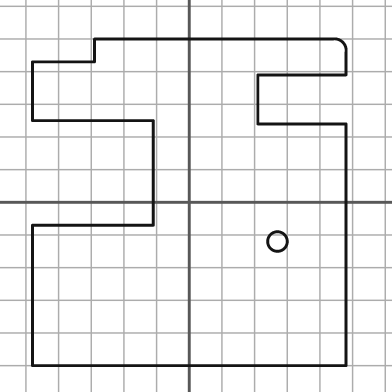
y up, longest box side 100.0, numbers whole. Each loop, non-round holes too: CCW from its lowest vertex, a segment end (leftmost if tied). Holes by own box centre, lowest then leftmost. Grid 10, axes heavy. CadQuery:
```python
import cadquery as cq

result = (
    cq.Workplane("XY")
    .moveTo(-48.0, -50.0)
    .lineTo(48.0, -50.0)
    .lineTo(48.0, 24.0)
    .lineTo(21.0, 24.0)
    .lineTo(21.0, 39.0)
    .lineTo(48.0, 39.0)
    .lineTo(48.0, 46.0)
    .threePointArc((47.0, 49.0), (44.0, 50.0))
    .lineTo(-29.0, 50.0)
    .lineTo(-29.0, 43.0)
    .lineTo(-48.0, 43.0)
    .lineTo(-48.0, 25.0)
    .lineTo(-11.0, 25.0)
    .lineTo(-11.0, -7.0)
    .lineTo(-48.0, -7.0)
    .close()
    .moveTo(27.0, -12.0)
    .circle(3.0)
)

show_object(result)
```